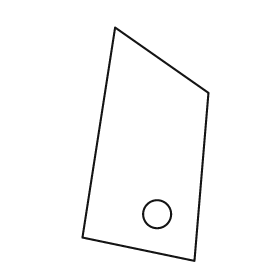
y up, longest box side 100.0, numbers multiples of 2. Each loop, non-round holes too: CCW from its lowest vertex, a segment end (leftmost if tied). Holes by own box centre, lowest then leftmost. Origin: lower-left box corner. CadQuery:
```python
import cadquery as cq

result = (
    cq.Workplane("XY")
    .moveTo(48.0, 0.0)
    .lineTo(54.0, 72.0)
    .lineTo(14.0, 100.0)
    .lineTo(0.0, 10.0)
    .close()
    .moveTo(32.0, 20.0)
    .circle(6.0)
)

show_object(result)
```